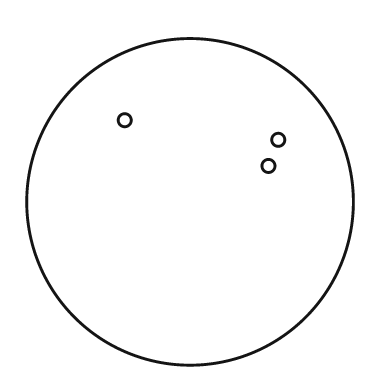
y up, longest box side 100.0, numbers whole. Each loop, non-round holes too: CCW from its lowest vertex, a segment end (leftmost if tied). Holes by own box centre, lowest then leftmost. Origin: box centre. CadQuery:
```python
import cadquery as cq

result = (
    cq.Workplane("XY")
    .moveTo(0.0, 0.0)
    .circle(50.0)
    .moveTo(24.0, 11.0)
    .circle(2.0)
    .moveTo(27.0, 19.0)
    .circle(2.0)
    .moveTo(-20.0, 25.0)
    .circle(2.0)
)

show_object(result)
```